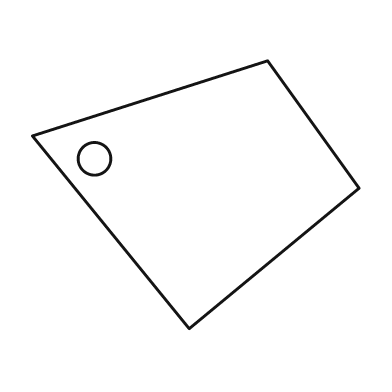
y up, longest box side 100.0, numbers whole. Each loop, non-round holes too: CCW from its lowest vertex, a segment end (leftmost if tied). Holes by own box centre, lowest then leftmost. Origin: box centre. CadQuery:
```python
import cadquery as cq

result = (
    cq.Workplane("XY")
    .moveTo(-2.0, -41.0)
    .lineTo(50.0, 2.0)
    .lineTo(22.0, 41.0)
    .lineTo(-50.0, 18.0)
    .close()
    .moveTo(-31.0, 11.0)
    .circle(5.0)
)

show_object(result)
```